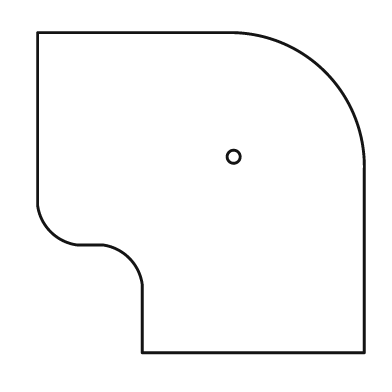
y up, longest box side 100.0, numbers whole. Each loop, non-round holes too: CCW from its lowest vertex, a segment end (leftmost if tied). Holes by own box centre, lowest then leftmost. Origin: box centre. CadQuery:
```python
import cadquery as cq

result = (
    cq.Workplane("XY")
    .moveTo(-18.0, -49.0)
    .lineTo(50.0, -49.0)
    .lineTo(50.0, 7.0)
    .threePointArc((38.0, 37.0), (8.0, 49.0))
    .lineTo(-50.0, 49.0)
    .lineTo(-50.0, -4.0)
    .threePointArc((-46.0, -12.0), (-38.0, -16.0))
    .lineTo(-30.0, -16.0)
    .threePointArc((-22.0, -20.0), (-18.0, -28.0))
    .close()
    .moveTo(10.0, 11.0)
    .circle(2.0)
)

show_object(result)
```